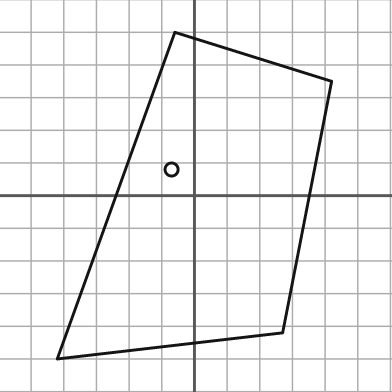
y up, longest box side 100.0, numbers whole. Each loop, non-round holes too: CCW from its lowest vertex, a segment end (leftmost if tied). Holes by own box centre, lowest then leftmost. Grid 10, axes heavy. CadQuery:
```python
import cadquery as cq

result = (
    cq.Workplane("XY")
    .moveTo(-42.0, -50.0)
    .lineTo(27.0, -42.0)
    .lineTo(42.0, 35.0)
    .lineTo(-6.0, 50.0)
    .close()
    .moveTo(-7.0, 8.0)
    .circle(2.0)
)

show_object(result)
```